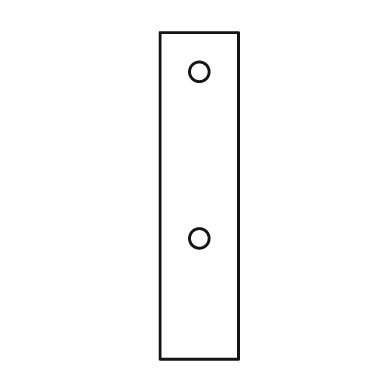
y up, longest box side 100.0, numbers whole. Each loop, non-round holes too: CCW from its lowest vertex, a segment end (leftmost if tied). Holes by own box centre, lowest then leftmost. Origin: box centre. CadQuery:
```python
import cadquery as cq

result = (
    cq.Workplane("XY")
    .moveTo(-12.0, -50.0)
    .lineTo(12.0, -50.0)
    .lineTo(12.0, 50.0)
    .lineTo(-12.0, 50.0)
    .close()
    .moveTo(0.0, -13.0)
    .circle(3.0)
    .moveTo(0.0, 38.0)
    .circle(3.0)
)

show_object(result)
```